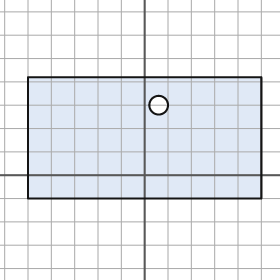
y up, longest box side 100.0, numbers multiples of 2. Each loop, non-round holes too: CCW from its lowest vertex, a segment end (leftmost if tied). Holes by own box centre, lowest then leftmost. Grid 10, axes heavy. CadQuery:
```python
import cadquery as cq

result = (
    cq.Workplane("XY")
    .moveTo(-50.0, -10.0)
    .lineTo(50.0, -10.0)
    .lineTo(50.0, 42.0)
    .lineTo(-50.0, 42.0)
    .close()
    .moveTo(6.0, 30.0)
    .circle(4.0)
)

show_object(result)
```